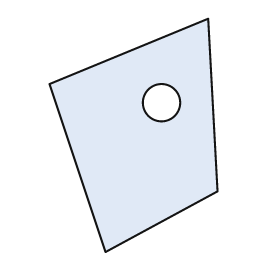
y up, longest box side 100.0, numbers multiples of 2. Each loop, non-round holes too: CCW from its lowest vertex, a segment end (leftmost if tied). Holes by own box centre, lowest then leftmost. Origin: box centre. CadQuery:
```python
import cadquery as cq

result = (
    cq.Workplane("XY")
    .moveTo(-12.0, -50.0)
    .lineTo(36.0, -24.0)
    .lineTo(32.0, 50.0)
    .lineTo(-36.0, 22.0)
    .close()
    .moveTo(12.0, 14.0)
    .circle(8.0)
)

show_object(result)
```